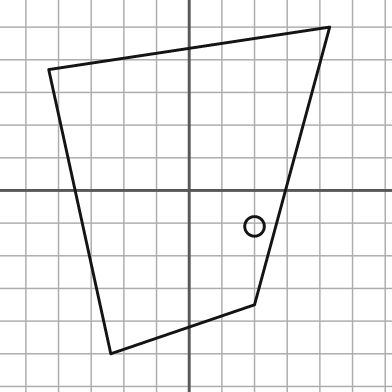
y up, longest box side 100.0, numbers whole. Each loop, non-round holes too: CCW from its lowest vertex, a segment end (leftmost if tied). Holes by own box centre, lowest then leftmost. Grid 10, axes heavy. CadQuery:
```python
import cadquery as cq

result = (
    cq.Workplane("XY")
    .moveTo(-24.0, -50.0)
    .lineTo(20.0, -35.0)
    .lineTo(43.0, 50.0)
    .lineTo(-43.0, 37.0)
    .close()
    .moveTo(20.0, -11.0)
    .circle(3.0)
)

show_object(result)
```